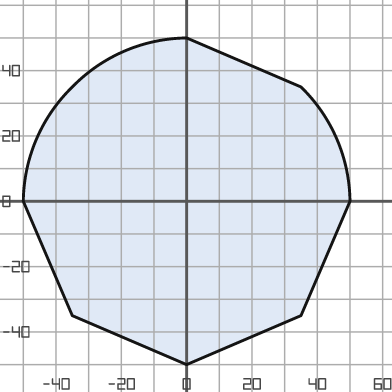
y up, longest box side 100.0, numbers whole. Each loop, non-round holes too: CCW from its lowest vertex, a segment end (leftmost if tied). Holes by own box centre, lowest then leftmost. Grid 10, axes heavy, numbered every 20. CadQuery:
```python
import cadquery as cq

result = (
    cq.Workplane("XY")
    .moveTo(0.0, -50.0)
    .lineTo(35.0, -35.0)
    .lineTo(50.0, 0.0)
    .threePointArc((46.0, 19.0), (35.0, 35.0))
    .lineTo(0.0, 50.0)
    .threePointArc((-19.0, 46.0), (-35.0, 35.0))
    .threePointArc((-46.0, 19.0), (-50.0, 0.0))
    .lineTo(-35.0, -35.0)
    .close()
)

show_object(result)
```